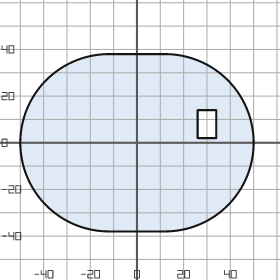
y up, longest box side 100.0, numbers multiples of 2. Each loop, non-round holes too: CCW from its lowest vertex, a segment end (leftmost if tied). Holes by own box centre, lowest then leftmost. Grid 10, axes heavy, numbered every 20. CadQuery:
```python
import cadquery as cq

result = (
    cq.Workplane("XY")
    .moveTo(-12.0, -38.0)
    .lineTo(12.0, -38.0)
    .threePointArc((50.0, 0.0), (12.0, 38.0))
    .lineTo(-12.0, 38.0)
    .threePointArc((-50.0, 0.0), (-12.0, -38.0))
    .close()
    .moveTo(26.0, 2.0)
    .lineTo(34.0, 2.0)
    .lineTo(34.0, 14.0)
    .lineTo(26.0, 14.0)
    .close()
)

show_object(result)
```